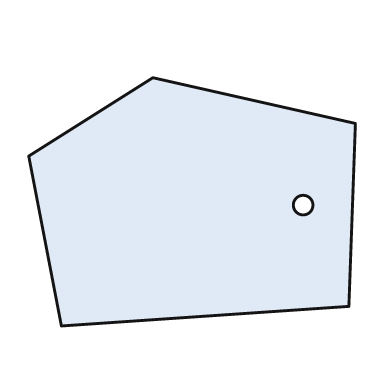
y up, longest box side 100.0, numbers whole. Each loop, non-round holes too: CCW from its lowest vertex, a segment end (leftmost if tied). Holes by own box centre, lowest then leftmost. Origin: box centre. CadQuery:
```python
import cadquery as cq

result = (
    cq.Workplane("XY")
    .moveTo(-40.0, -38.0)
    .lineTo(48.0, -32.0)
    .lineTo(50.0, 24.0)
    .lineTo(-12.0, 38.0)
    .lineTo(-50.0, 14.0)
    .close()
    .moveTo(34.0, -1.0)
    .circle(3.0)
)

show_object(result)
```